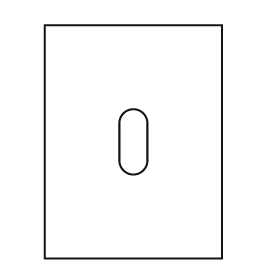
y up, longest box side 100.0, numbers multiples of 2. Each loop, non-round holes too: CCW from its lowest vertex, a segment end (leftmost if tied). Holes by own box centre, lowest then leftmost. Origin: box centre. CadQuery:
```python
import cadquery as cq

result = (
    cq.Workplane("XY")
    .moveTo(-38.0, -50.0)
    .lineTo(38.0, -50.0)
    .lineTo(38.0, 50.0)
    .lineTo(-38.0, 50.0)
    .close()
    .moveTo(-6.0, -8.0)
    .threePointArc((0.0, -14.0), (6.0, -8.0))
    .lineTo(6.0, 8.0)
    .threePointArc((0.0, 14.0), (-6.0, 8.0))
    .close()
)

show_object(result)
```